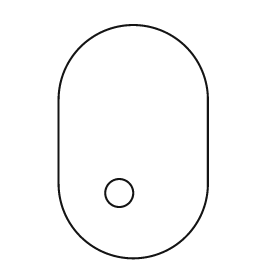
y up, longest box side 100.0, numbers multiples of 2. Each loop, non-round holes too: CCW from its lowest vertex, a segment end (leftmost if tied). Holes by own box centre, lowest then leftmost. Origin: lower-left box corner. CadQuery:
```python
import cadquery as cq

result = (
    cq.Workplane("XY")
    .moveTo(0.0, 32.0)
    .threePointArc((32.0, 0.0), (64.0, 32.0))
    .lineTo(64.0, 68.0)
    .threePointArc((32.0, 100.0), (0.0, 68.0))
    .close()
    .moveTo(26.0, 28.0)
    .circle(6.0)
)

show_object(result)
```